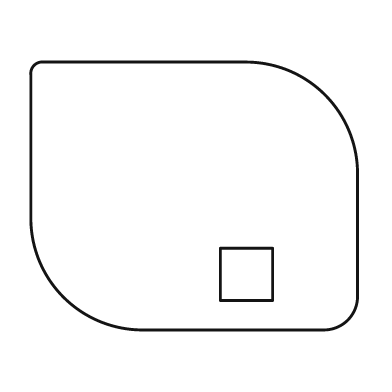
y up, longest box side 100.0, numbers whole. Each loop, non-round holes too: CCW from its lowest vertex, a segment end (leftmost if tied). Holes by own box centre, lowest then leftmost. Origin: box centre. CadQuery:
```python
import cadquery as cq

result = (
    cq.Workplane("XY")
    .moveTo(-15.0, -41.0)
    .lineTo(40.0, -41.0)
    .threePointArc((47.0, -38.0), (50.0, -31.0))
    .lineTo(50.0, 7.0)
    .threePointArc((40.0, 31.0), (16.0, 41.0))
    .lineTo(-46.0, 41.0)
    .threePointArc((-49.0, 40.0), (-50.0, 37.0))
    .lineTo(-50.0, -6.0)
    .threePointArc((-40.0, -31.0), (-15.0, -41.0))
    .close()
    .moveTo(8.0, -32.0)
    .lineTo(24.0, -32.0)
    .lineTo(24.0, -16.0)
    .lineTo(8.0, -16.0)
    .close()
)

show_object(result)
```